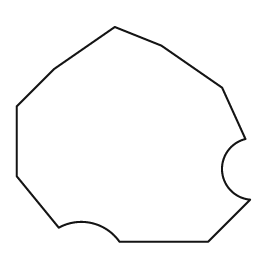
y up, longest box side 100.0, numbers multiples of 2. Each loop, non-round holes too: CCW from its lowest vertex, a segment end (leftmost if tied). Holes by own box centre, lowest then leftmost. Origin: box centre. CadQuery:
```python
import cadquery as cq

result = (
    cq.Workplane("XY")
    .moveTo(-6.0, -46.0)
    .lineTo(32.0, -46.0)
    .lineTo(50.0, -28.0)
    .threePointArc((38.0, -16.0), (48.0, -2.0))
    .lineTo(38.0, 20.0)
    .lineTo(12.0, 38.0)
    .lineTo(-8.0, 46.0)
    .lineTo(-34.0, 28.0)
    .lineTo(-50.0, 12.0)
    .lineTo(-50.0, -18.0)
    .lineTo(-32.0, -40.0)
    .threePointArc((-18.0, -38.0), (-6.0, -46.0))
    .close()
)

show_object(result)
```